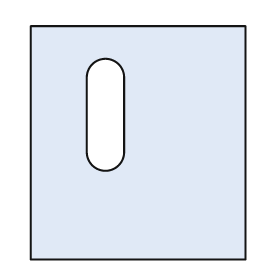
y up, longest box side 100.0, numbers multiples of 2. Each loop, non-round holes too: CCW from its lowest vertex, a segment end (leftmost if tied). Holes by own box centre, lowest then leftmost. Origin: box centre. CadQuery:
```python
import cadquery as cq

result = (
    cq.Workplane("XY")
    .moveTo(-46.0, -50.0)
    .lineTo(46.0, -50.0)
    .lineTo(46.0, 50.0)
    .lineTo(-46.0, 50.0)
    .close()
    .moveTo(-22.0, -4.0)
    .threePointArc((-14.0, -12.0), (-6.0, -4.0))
    .lineTo(-6.0, 28.0)
    .threePointArc((-14.0, 36.0), (-22.0, 28.0))
    .close()
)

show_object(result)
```